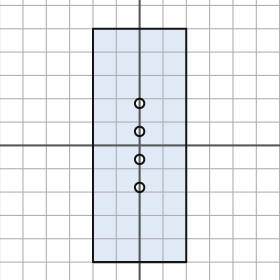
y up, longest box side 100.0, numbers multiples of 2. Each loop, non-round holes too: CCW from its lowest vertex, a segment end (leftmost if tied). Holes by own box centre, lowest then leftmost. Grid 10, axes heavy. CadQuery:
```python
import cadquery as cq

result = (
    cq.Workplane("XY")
    .moveTo(-20.0, -50.0)
    .lineTo(20.0, -50.0)
    .lineTo(20.0, 50.0)
    .lineTo(-20.0, 50.0)
    .close()
    .moveTo(0.0, -18.0)
    .circle(2.0)
    .moveTo(0.0, -6.0)
    .circle(2.0)
    .moveTo(0.0, 6.0)
    .circle(2.0)
    .moveTo(0.0, 18.0)
    .circle(2.0)
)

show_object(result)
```